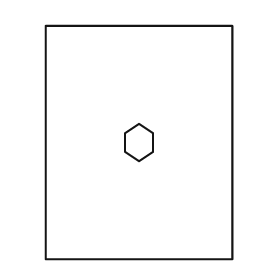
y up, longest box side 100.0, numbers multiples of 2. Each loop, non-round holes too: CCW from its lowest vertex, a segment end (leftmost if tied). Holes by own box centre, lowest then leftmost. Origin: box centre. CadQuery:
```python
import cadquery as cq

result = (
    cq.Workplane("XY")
    .moveTo(-40.0, -50.0)
    .lineTo(40.0, -50.0)
    .lineTo(40.0, 50.0)
    .lineTo(-40.0, 50.0)
    .close()
    .moveTo(0.0, -8.0)
    .lineTo(6.0, -4.0)
    .lineTo(6.0, 4.0)
    .lineTo(0.0, 8.0)
    .lineTo(-6.0, 4.0)
    .lineTo(-6.0, -4.0)
    .close()
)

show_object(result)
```